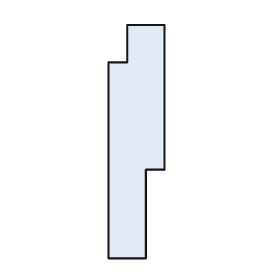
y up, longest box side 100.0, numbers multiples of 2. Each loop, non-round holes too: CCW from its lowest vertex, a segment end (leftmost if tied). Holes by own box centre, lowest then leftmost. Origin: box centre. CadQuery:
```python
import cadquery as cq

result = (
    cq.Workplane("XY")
    .moveTo(-12.0, -50.0)
    .lineTo(4.0, -50.0)
    .lineTo(4.0, -12.0)
    .lineTo(12.0, -12.0)
    .lineTo(12.0, 50.0)
    .lineTo(-4.0, 50.0)
    .lineTo(-4.0, 34.0)
    .lineTo(-12.0, 34.0)
    .close()
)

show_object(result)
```